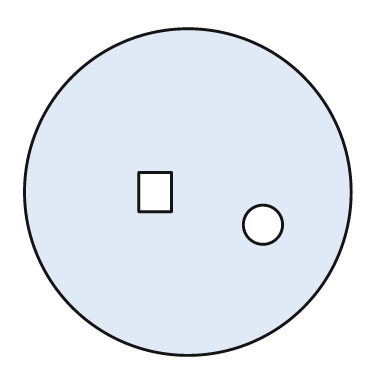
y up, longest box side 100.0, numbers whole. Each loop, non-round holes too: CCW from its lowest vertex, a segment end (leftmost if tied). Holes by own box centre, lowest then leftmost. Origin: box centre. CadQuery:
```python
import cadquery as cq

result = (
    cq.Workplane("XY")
    .moveTo(0.0, 0.0)
    .circle(50.0)
    .moveTo(23.0, -10.0)
    .circle(6.0)
    .moveTo(-15.0, -6.0)
    .lineTo(-5.0, -6.0)
    .lineTo(-5.0, 6.0)
    .lineTo(-15.0, 6.0)
    .close()
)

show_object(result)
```